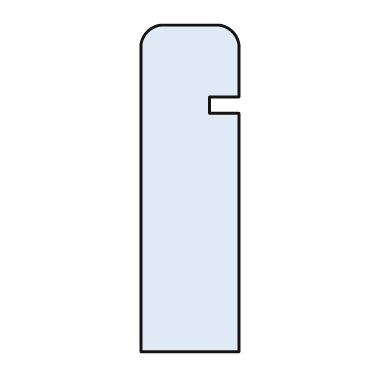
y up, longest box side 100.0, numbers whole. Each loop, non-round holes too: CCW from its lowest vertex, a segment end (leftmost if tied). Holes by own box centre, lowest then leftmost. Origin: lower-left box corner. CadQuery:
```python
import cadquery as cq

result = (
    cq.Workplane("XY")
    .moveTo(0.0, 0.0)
    .lineTo(30.0, 0.0)
    .lineTo(30.0, 73.0)
    .lineTo(21.0, 73.0)
    .lineTo(21.0, 78.0)
    .lineTo(30.0, 78.0)
    .lineTo(30.0, 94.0)
    .threePointArc((28.0, 98.0), (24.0, 100.0))
    .lineTo(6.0, 100.0)
    .threePointArc((2.0, 98.0), (0.0, 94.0))
    .close()
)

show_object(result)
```